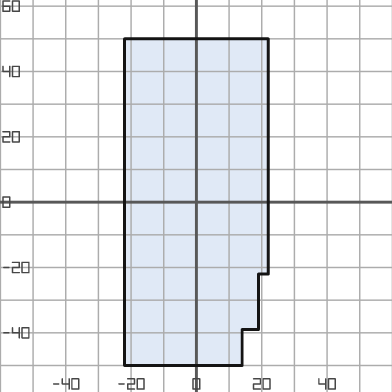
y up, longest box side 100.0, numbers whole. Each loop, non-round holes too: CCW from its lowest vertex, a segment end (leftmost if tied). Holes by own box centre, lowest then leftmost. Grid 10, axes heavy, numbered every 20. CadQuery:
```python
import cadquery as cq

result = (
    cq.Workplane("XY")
    .moveTo(-22.0, -50.0)
    .lineTo(14.0, -50.0)
    .lineTo(14.0, -39.0)
    .lineTo(19.0, -39.0)
    .lineTo(19.0, -22.0)
    .lineTo(22.0, -22.0)
    .lineTo(22.0, 50.0)
    .lineTo(-22.0, 50.0)
    .close()
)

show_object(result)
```